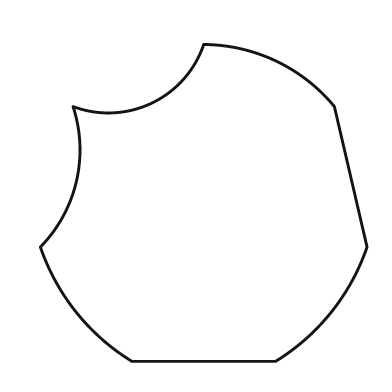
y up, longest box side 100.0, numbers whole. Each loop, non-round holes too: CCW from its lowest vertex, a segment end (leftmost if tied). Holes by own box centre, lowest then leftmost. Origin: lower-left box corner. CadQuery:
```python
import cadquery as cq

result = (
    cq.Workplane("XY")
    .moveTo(28.0, 0.0)
    .lineTo(72.0, 0.0)
    .threePointArc((89.0, 15.0), (100.0, 35.0))
    .lineTo(90.0, 78.0)
    .threePointArc((72.0, 92.0), (50.0, 97.0))
    .threePointArc((34.0, 79.0), (10.0, 78.0))
    .threePointArc((11.0, 55.0), (0.0, 35.0))
    .threePointArc((11.0, 15.0), (28.0, 0.0))
    .close()
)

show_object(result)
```